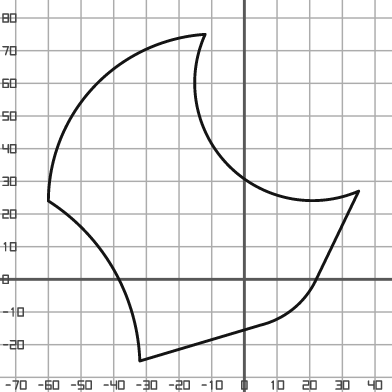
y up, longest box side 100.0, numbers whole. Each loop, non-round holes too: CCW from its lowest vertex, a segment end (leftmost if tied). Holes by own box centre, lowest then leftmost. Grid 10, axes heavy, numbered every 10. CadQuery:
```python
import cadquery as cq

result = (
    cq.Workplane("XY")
    .moveTo(-32.0, -25.0)
    .lineTo(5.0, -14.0)
    .threePointArc((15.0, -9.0), (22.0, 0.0))
    .lineTo(35.0, 27.0)
    .threePointArc((-5.0, 35.0), (-12.0, 75.0))
    .threePointArc((-46.0, 59.0), (-60.0, 24.0))
    .threePointArc((-40.0, 3.0), (-32.0, -25.0))
    .close()
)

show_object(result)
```